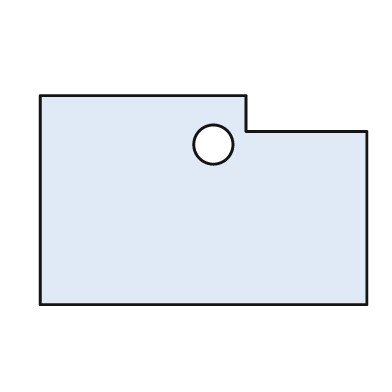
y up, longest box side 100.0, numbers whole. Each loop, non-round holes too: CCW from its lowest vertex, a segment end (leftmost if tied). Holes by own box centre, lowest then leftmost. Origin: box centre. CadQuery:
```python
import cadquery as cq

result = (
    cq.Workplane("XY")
    .moveTo(-50.0, -32.0)
    .lineTo(50.0, -32.0)
    .lineTo(50.0, 21.0)
    .lineTo(13.0, 21.0)
    .lineTo(13.0, 32.0)
    .lineTo(-50.0, 32.0)
    .close()
    .moveTo(3.0, 17.0)
    .circle(6.0)
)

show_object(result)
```